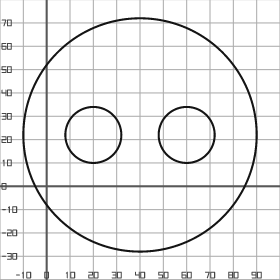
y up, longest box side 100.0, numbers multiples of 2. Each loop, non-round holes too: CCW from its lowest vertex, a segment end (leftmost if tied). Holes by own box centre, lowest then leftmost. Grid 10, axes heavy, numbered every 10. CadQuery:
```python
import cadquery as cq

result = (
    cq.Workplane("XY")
    .moveTo(40.0, 22.0)
    .circle(50.0)
    .moveTo(20.0, 22.0)
    .circle(12.0)
    .moveTo(60.0, 22.0)
    .circle(12.0)
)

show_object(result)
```